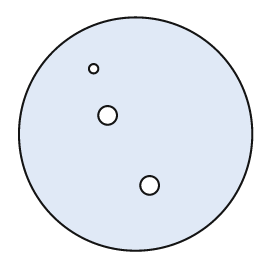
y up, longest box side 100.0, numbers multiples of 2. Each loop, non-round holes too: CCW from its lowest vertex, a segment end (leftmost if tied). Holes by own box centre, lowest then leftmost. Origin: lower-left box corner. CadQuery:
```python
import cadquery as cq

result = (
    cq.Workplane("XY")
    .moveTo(50.0, 50.0)
    .circle(50.0)
    .moveTo(56.0, 28.0)
    .circle(4.0)
    .moveTo(38.0, 58.0)
    .circle(4.0)
    .moveTo(32.0, 78.0)
    .circle(2.0)
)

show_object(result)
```